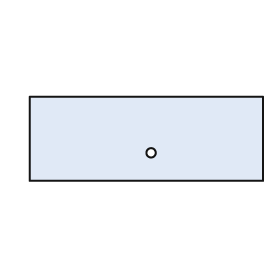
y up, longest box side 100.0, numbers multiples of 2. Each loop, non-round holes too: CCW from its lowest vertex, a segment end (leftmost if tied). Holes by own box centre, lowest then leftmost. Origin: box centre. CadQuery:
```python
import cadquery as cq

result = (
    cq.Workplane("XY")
    .moveTo(-50.0, -18.0)
    .lineTo(50.0, -18.0)
    .lineTo(50.0, 18.0)
    .lineTo(-50.0, 18.0)
    .close()
    .moveTo(2.0, -6.0)
    .circle(2.0)
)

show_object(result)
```